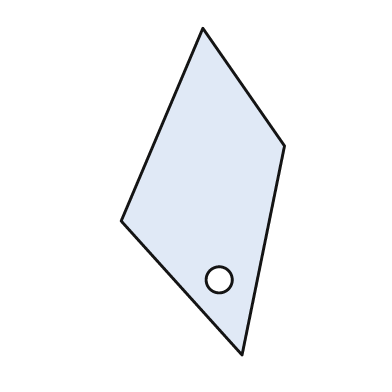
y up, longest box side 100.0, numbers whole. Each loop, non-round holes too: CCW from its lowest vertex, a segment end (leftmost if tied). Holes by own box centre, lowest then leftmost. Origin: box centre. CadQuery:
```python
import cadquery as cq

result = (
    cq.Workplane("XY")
    .moveTo(12.0, -50.0)
    .lineTo(25.0, 14.0)
    .lineTo(0.0, 50.0)
    .lineTo(-25.0, -9.0)
    .close()
    .moveTo(5.0, -27.0)
    .circle(4.0)
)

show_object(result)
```